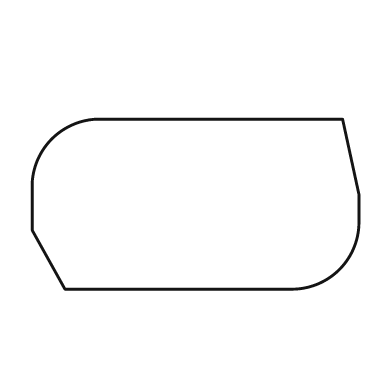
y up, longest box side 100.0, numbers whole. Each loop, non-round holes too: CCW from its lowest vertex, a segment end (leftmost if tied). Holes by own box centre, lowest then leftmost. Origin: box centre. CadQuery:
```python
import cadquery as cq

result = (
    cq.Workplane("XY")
    .moveTo(-40.0, -26.0)
    .lineTo(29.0, -26.0)
    .threePointArc((44.0, -20.0), (50.0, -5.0))
    .lineTo(50.0, 3.0)
    .lineTo(45.0, 26.0)
    .lineTo(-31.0, 26.0)
    .threePointArc((-44.0, 20.0), (-50.0, 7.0))
    .lineTo(-50.0, -8.0)
    .close()
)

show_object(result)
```